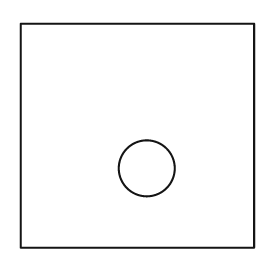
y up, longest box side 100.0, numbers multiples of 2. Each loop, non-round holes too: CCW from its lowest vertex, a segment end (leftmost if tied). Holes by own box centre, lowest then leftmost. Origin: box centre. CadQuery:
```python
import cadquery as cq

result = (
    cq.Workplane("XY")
    .moveTo(-50.0, -48.0)
    .lineTo(50.0, -48.0)
    .lineTo(50.0, 48.0)
    .lineTo(-50.0, 48.0)
    .close()
    .moveTo(4.0, -14.0)
    .circle(12.0)
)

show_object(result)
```